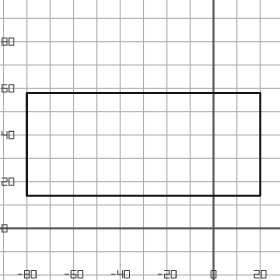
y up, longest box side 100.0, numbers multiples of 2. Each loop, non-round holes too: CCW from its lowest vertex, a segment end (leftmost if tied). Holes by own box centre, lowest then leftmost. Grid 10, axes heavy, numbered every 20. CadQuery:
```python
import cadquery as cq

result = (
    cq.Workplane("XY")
    .moveTo(-80.0, 14.0)
    .lineTo(20.0, 14.0)
    .lineTo(20.0, 58.0)
    .lineTo(-80.0, 58.0)
    .close()
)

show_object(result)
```